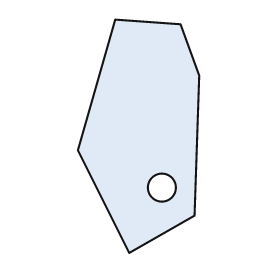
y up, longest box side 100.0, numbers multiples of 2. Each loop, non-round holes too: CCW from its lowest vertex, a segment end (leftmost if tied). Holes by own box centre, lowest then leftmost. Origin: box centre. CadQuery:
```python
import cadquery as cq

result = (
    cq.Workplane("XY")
    .moveTo(-4.0, -50.0)
    .lineTo(24.0, -34.0)
    .lineTo(26.0, 26.0)
    .lineTo(18.0, 48.0)
    .lineTo(-10.0, 50.0)
    .lineTo(-26.0, -6.0)
    .close()
    .moveTo(10.0, -22.0)
    .circle(6.0)
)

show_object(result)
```